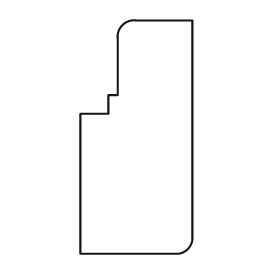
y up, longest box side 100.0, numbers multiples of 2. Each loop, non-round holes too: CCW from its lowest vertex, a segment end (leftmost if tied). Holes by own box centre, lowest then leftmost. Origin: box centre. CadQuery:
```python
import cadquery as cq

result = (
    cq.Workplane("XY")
    .moveTo(-24.0, -50.0)
    .lineTo(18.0, -50.0)
    .threePointArc((22.0, -48.0), (24.0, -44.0))
    .lineTo(24.0, 50.0)
    .lineTo(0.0, 50.0)
    .threePointArc((-6.0, 48.0), (-8.0, 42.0))
    .lineTo(-8.0, 18.0)
    .lineTo(-12.0, 18.0)
    .lineTo(-12.0, 10.0)
    .lineTo(-24.0, 10.0)
    .close()
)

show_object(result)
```